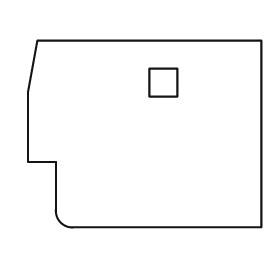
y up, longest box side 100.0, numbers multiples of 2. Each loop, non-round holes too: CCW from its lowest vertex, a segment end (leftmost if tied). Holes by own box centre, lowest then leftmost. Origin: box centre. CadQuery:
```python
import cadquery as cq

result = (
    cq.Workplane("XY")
    .moveTo(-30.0, -40.0)
    .lineTo(50.0, -40.0)
    .lineTo(50.0, 40.0)
    .lineTo(-46.0, 40.0)
    .lineTo(-50.0, 18.0)
    .lineTo(-50.0, -12.0)
    .lineTo(-38.0, -12.0)
    .lineTo(-38.0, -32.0)
    .threePointArc((-36.0, -38.0), (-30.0, -40.0))
    .close()
    .moveTo(2.0, 16.0)
    .lineTo(14.0, 16.0)
    .lineTo(14.0, 28.0)
    .lineTo(2.0, 28.0)
    .close()
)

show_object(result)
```